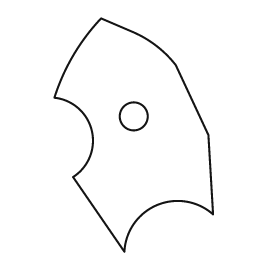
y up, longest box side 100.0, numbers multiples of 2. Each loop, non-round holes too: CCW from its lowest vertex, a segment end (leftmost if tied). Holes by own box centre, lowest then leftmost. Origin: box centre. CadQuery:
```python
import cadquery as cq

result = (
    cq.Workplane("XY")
    .moveTo(-4.0, -50.0)
    .threePointArc((10.0, -30.0), (34.0, -34.0))
    .lineTo(32.0, 0.0)
    .lineTo(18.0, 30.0)
    .threePointArc((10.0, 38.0), (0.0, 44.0))
    .lineTo(-14.0, 50.0)
    .threePointArc((-26.0, 34.0), (-34.0, 16.0))
    .threePointArc((-18.0, 2.0), (-26.0, -18.0))
    .close()
    .moveTo(0.0, 8.0)
    .circle(6.0)
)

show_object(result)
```